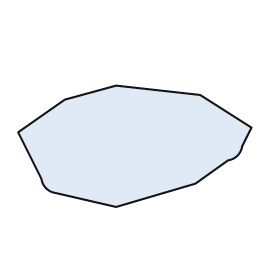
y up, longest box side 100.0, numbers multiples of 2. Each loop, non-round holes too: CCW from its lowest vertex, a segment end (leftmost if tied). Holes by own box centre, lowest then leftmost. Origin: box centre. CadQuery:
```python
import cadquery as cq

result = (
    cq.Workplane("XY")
    .moveTo(-8.0, -26.0)
    .lineTo(26.0, -16.0)
    .lineTo(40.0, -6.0)
    .threePointArc((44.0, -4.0), (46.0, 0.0))
    .lineTo(50.0, 8.0)
    .lineTo(28.0, 22.0)
    .lineTo(-8.0, 26.0)
    .lineTo(-30.0, 20.0)
    .lineTo(-50.0, 6.0)
    .lineTo(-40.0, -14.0)
    .threePointArc((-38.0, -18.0), (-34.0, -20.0))
    .close()
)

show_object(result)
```